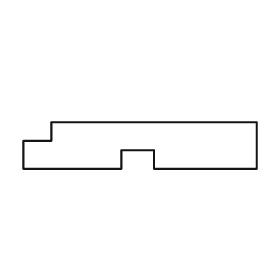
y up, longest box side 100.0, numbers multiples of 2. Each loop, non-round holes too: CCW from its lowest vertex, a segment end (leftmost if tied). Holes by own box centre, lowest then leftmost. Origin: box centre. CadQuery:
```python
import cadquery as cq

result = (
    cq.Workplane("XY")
    .moveTo(-50.0, -10.0)
    .lineTo(-8.0, -10.0)
    .lineTo(-8.0, -2.0)
    .lineTo(6.0, -2.0)
    .lineTo(6.0, -10.0)
    .lineTo(50.0, -10.0)
    .lineTo(50.0, 10.0)
    .lineTo(-38.0, 10.0)
    .lineTo(-38.0, 2.0)
    .lineTo(-50.0, 2.0)
    .close()
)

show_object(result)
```